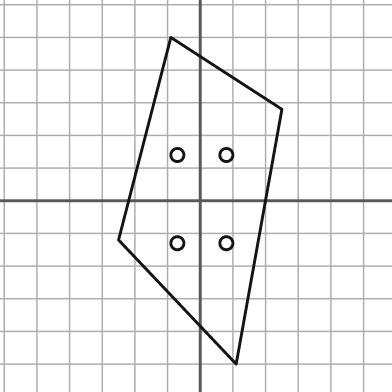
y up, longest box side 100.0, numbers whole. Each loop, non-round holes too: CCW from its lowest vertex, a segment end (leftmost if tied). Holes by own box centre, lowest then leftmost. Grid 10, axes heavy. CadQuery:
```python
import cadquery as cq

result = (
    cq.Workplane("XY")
    .moveTo(11.0, -50.0)
    .lineTo(25.0, 28.0)
    .lineTo(-9.0, 50.0)
    .lineTo(-25.0, -12.0)
    .close()
    .moveTo(-7.0, -13.0)
    .circle(2.0)
    .moveTo(8.0, -13.0)
    .circle(2.0)
    .moveTo(-7.0, 14.0)
    .circle(2.0)
    .moveTo(8.0, 14.0)
    .circle(2.0)
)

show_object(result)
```